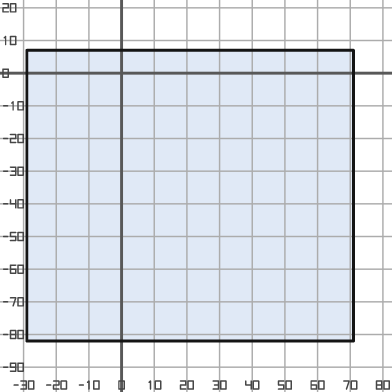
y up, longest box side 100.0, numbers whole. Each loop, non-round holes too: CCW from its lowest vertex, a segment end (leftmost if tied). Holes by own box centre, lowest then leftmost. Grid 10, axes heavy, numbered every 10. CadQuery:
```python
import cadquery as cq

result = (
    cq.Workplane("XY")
    .moveTo(-29.0, -82.0)
    .lineTo(71.0, -82.0)
    .lineTo(71.0, 7.0)
    .lineTo(-29.0, 7.0)
    .close()
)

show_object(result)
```